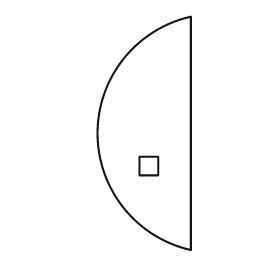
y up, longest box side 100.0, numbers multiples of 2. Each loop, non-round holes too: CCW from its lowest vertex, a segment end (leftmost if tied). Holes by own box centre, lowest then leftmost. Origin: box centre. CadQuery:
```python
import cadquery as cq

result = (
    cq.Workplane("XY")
    .moveTo(20.0, -50.0)
    .lineTo(20.0, 50.0)
    .threePointArc((-20.0, 0.0), (20.0, -50.0))
    .close()
    .moveTo(-2.0, -18.0)
    .lineTo(6.0, -18.0)
    .lineTo(6.0, -10.0)
    .lineTo(-2.0, -10.0)
    .close()
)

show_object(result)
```